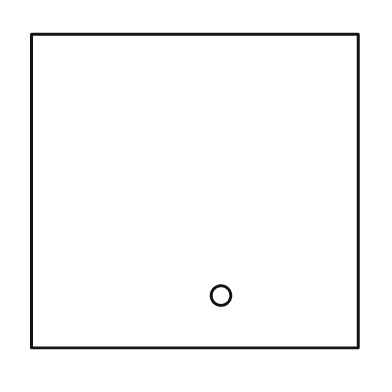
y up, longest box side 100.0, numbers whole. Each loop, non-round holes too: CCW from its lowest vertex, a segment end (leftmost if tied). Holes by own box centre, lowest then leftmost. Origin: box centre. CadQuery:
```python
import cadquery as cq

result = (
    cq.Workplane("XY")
    .moveTo(-50.0, -48.0)
    .lineTo(50.0, -48.0)
    .lineTo(50.0, 48.0)
    .lineTo(-50.0, 48.0)
    .close()
    .moveTo(8.0, -32.0)
    .circle(3.0)
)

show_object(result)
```